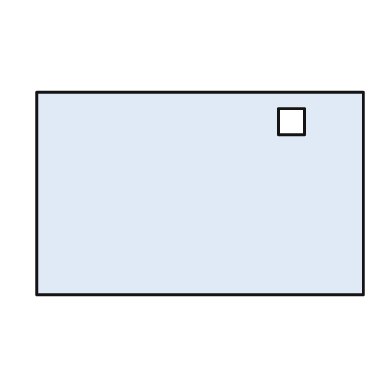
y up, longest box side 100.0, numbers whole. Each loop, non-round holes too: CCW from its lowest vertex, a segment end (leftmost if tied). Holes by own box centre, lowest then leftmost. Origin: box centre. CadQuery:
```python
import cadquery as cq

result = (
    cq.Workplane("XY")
    .moveTo(-50.0, -31.0)
    .lineTo(50.0, -31.0)
    .lineTo(50.0, 31.0)
    .lineTo(-50.0, 31.0)
    .close()
    .moveTo(24.0, 18.0)
    .lineTo(32.0, 18.0)
    .lineTo(32.0, 26.0)
    .lineTo(24.0, 26.0)
    .close()
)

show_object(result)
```